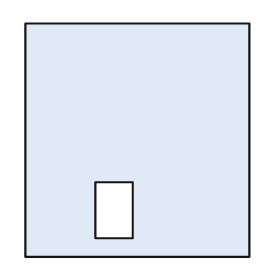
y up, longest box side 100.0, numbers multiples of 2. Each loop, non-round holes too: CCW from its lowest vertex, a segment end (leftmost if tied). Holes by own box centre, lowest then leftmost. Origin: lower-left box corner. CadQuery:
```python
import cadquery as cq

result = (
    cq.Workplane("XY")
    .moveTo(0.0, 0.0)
    .lineTo(96.0, 0.0)
    .lineTo(96.0, 100.0)
    .lineTo(0.0, 100.0)
    .close()
    .moveTo(30.0, 8.0)
    .lineTo(46.0, 8.0)
    .lineTo(46.0, 32.0)
    .lineTo(30.0, 32.0)
    .close()
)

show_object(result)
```